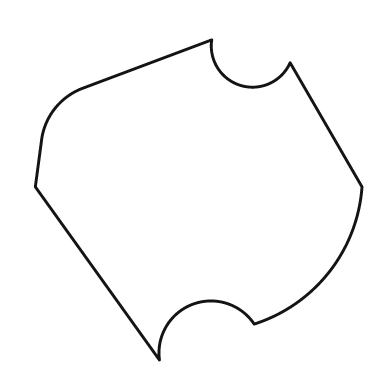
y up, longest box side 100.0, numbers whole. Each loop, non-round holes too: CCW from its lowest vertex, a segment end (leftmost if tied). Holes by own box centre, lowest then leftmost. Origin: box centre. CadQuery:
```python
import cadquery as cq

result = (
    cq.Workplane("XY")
    .moveTo(-12.0, -49.0)
    .threePointArc((-2.0, -32.0), (17.0, -38.0))
    .threePointArc((40.0, -22.0), (50.0, 4.0))
    .lineTo(28.0, 42.0)
    .threePointArc((13.0, 35.0), (4.0, 49.0))
    .lineTo(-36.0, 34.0)
    .threePointArc((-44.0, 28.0), (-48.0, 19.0))
    .lineTo(-50.0, 4.0)
    .close()
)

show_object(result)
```